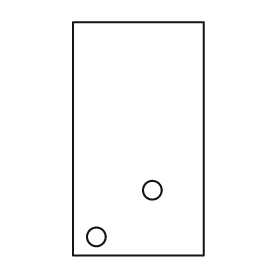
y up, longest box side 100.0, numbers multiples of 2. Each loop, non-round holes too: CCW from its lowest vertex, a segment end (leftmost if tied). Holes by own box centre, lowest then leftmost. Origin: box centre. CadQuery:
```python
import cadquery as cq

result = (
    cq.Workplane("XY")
    .moveTo(-28.0, -50.0)
    .lineTo(28.0, -50.0)
    .lineTo(28.0, 50.0)
    .lineTo(-28.0, 50.0)
    .close()
    .moveTo(-18.0, -42.0)
    .circle(4.0)
    .moveTo(6.0, -22.0)
    .circle(4.0)
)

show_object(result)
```